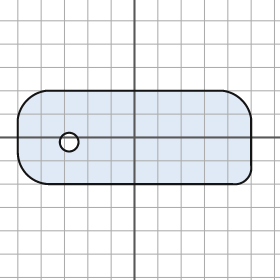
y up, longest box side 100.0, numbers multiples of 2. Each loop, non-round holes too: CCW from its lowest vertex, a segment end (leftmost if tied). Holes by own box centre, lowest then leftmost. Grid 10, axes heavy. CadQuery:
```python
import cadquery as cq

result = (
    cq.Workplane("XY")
    .moveTo(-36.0, -20.0)
    .lineTo(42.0, -20.0)
    .threePointArc((48.0, -18.0), (50.0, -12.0))
    .lineTo(50.0, 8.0)
    .threePointArc((46.0, 16.0), (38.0, 20.0))
    .lineTo(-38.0, 20.0)
    .threePointArc((-46.0, 16.0), (-50.0, 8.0))
    .lineTo(-50.0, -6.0)
    .threePointArc((-46.0, -16.0), (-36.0, -20.0))
    .close()
    .moveTo(-28.0, -2.0)
    .circle(4.0)
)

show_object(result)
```